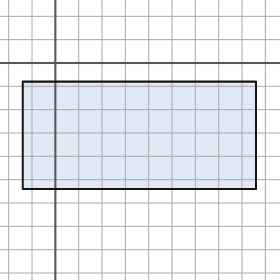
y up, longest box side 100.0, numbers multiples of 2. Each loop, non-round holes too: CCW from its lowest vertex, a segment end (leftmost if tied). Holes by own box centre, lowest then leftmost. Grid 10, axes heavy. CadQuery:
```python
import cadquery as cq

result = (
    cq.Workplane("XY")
    .moveTo(-14.0, -54.0)
    .lineTo(86.0, -54.0)
    .lineTo(86.0, -8.0)
    .lineTo(-14.0, -8.0)
    .close()
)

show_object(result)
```